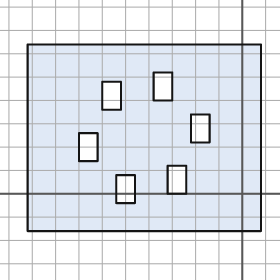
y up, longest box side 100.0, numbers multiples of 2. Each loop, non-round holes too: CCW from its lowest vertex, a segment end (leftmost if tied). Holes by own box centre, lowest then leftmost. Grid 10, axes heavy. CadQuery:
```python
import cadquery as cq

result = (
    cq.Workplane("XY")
    .moveTo(-92.0, -16.0)
    .lineTo(8.0, -16.0)
    .lineTo(8.0, 64.0)
    .lineTo(-92.0, 64.0)
    .close()
    .moveTo(-54.0, -4.0)
    .lineTo(-46.0, -4.0)
    .lineTo(-46.0, 8.0)
    .lineTo(-54.0, 8.0)
    .close()
    .moveTo(-32.0, 0.0)
    .lineTo(-24.0, 0.0)
    .lineTo(-24.0, 12.0)
    .lineTo(-32.0, 12.0)
    .close()
    .moveTo(-70.0, 14.0)
    .lineTo(-62.0, 14.0)
    .lineTo(-62.0, 26.0)
    .lineTo(-70.0, 26.0)
    .close()
    .moveTo(-22.0, 22.0)
    .lineTo(-14.0, 22.0)
    .lineTo(-14.0, 34.0)
    .lineTo(-22.0, 34.0)
    .close()
    .moveTo(-60.0, 36.0)
    .lineTo(-52.0, 36.0)
    .lineTo(-52.0, 48.0)
    .lineTo(-60.0, 48.0)
    .close()
    .moveTo(-38.0, 40.0)
    .lineTo(-30.0, 40.0)
    .lineTo(-30.0, 52.0)
    .lineTo(-38.0, 52.0)
    .close()
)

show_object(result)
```